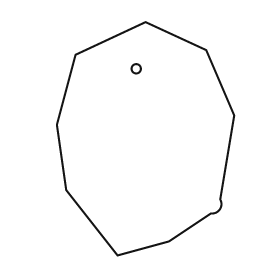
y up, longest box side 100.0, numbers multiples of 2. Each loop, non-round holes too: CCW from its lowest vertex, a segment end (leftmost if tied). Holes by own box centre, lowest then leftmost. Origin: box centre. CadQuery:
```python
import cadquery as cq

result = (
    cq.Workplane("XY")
    .moveTo(-12.0, -50.0)
    .lineTo(10.0, -44.0)
    .lineTo(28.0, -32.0)
    .threePointArc((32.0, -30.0), (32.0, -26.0))
    .lineTo(38.0, 10.0)
    .lineTo(26.0, 38.0)
    .lineTo(0.0, 50.0)
    .lineTo(-30.0, 36.0)
    .lineTo(-38.0, 6.0)
    .lineTo(-34.0, -22.0)
    .close()
    .moveTo(-4.0, 30.0)
    .circle(2.0)
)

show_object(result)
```